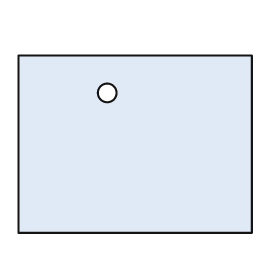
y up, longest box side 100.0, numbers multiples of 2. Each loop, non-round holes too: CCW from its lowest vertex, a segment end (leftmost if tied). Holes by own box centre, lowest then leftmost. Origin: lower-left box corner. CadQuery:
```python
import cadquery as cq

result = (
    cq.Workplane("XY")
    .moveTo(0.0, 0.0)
    .lineTo(100.0, 0.0)
    .lineTo(100.0, 76.0)
    .lineTo(0.0, 76.0)
    .close()
    .moveTo(38.0, 60.0)
    .circle(4.0)
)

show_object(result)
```